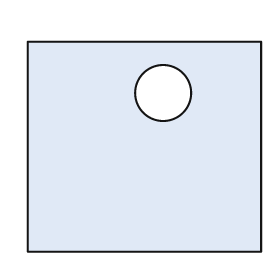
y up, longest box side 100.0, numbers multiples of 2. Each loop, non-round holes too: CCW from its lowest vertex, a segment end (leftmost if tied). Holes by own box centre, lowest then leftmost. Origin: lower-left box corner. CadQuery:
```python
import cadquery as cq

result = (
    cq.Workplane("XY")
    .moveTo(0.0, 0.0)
    .lineTo(100.0, 0.0)
    .lineTo(100.0, 90.0)
    .lineTo(0.0, 90.0)
    .close()
    .moveTo(58.0, 68.0)
    .circle(12.0)
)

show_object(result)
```